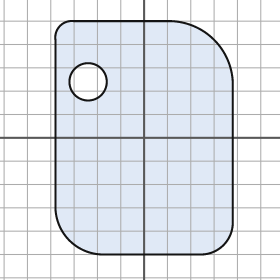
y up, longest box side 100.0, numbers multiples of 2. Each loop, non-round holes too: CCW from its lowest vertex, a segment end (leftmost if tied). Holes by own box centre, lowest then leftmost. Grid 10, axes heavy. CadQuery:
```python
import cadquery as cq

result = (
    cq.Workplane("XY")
    .moveTo(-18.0, -50.0)
    .lineTo(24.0, -50.0)
    .threePointArc((34.0, -46.0), (38.0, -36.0))
    .lineTo(38.0, 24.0)
    .threePointArc((30.0, 42.0), (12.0, 50.0))
    .lineTo(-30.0, 50.0)
    .threePointArc((-36.0, 48.0), (-38.0, 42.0))
    .lineTo(-38.0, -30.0)
    .threePointArc((-32.0, -44.0), (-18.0, -50.0))
    .close()
    .moveTo(-24.0, 24.0)
    .circle(8.0)
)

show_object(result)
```